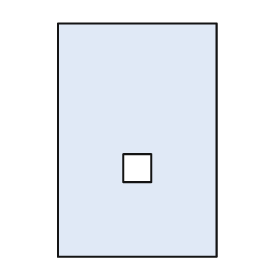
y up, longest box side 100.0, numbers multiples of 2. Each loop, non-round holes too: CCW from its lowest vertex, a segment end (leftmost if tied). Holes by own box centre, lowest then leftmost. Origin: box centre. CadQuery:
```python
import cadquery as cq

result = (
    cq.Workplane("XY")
    .moveTo(-34.0, -50.0)
    .lineTo(34.0, -50.0)
    .lineTo(34.0, 50.0)
    .lineTo(-34.0, 50.0)
    .close()
    .moveTo(-6.0, -18.0)
    .lineTo(6.0, -18.0)
    .lineTo(6.0, -6.0)
    .lineTo(-6.0, -6.0)
    .close()
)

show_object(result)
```